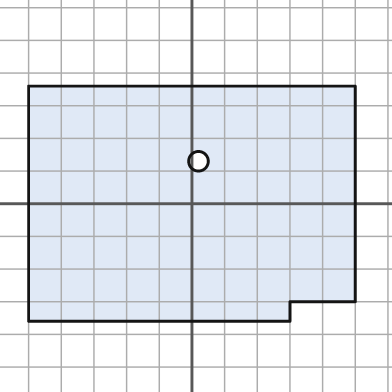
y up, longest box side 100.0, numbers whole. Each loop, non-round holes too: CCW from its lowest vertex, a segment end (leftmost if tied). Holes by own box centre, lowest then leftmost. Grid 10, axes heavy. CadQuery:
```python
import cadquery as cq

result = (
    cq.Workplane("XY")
    .moveTo(-50.0, -36.0)
    .lineTo(30.0, -36.0)
    .lineTo(30.0, -30.0)
    .lineTo(50.0, -30.0)
    .lineTo(50.0, 36.0)
    .lineTo(-50.0, 36.0)
    .close()
    .moveTo(2.0, 13.0)
    .circle(3.0)
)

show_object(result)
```